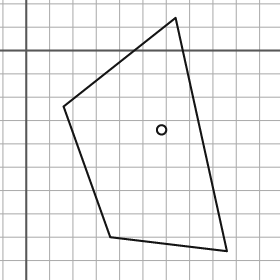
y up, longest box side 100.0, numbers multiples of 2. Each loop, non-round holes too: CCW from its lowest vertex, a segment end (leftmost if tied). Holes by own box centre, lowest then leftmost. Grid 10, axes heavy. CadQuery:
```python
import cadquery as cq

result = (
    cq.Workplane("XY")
    .moveTo(86.0, -86.0)
    .lineTo(64.0, 14.0)
    .lineTo(16.0, -24.0)
    .lineTo(36.0, -80.0)
    .close()
    .moveTo(58.0, -34.0)
    .circle(2.0)
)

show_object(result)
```